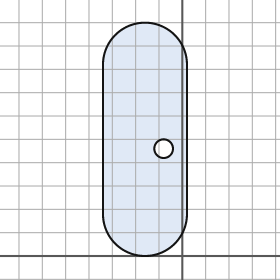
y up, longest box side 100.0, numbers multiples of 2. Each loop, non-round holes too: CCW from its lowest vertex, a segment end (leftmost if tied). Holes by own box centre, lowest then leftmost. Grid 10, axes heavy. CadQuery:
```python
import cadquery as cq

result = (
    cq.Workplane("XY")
    .moveTo(-34.0, 18.0)
    .threePointArc((-16.0, 0.0), (2.0, 18.0))
    .lineTo(2.0, 82.0)
    .threePointArc((-16.0, 100.0), (-34.0, 82.0))
    .close()
    .moveTo(-8.0, 46.0)
    .circle(4.0)
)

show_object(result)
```